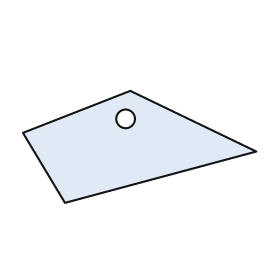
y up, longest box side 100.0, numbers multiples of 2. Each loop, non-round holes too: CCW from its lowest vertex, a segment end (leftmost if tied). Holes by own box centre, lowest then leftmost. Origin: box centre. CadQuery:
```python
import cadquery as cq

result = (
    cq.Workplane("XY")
    .moveTo(-32.0, -24.0)
    .lineTo(50.0, -2.0)
    .lineTo(-4.0, 24.0)
    .lineTo(-50.0, 6.0)
    .close()
    .moveTo(-6.0, 12.0)
    .circle(4.0)
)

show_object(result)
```